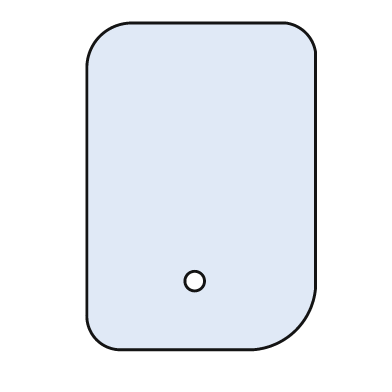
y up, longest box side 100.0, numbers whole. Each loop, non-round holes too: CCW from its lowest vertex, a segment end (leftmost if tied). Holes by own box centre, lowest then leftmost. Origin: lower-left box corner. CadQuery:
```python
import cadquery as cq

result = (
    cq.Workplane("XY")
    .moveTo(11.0, 0.0)
    .lineTo(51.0, 0.0)
    .threePointArc((64.0, 6.0), (70.0, 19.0))
    .lineTo(70.0, 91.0)
    .threePointArc((67.0, 97.0), (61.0, 100.0))
    .lineTo(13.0, 100.0)
    .threePointArc((4.0, 96.0), (0.0, 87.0))
    .lineTo(0.0, 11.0)
    .threePointArc((3.0, 3.0), (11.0, 0.0))
    .close()
    .moveTo(33.0, 21.0)
    .circle(3.0)
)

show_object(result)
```